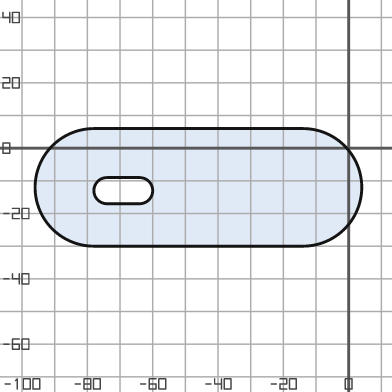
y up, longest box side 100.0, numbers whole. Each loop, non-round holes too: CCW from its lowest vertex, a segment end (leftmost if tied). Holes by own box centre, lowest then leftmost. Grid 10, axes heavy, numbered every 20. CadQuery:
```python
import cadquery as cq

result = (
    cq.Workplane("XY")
    .moveTo(-78.0, -30.0)
    .lineTo(-14.0, -30.0)
    .threePointArc((4.0, -12.0), (-14.0, 6.0))
    .lineTo(-78.0, 6.0)
    .threePointArc((-96.0, -12.0), (-78.0, -30.0))
    .close()
    .moveTo(-74.0, -17.0)
    .lineTo(-64.0, -17.0)
    .threePointArc((-60.0, -13.0), (-64.0, -9.0))
    .lineTo(-74.0, -9.0)
    .threePointArc((-78.0, -13.0), (-74.0, -17.0))
    .close()
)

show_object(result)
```